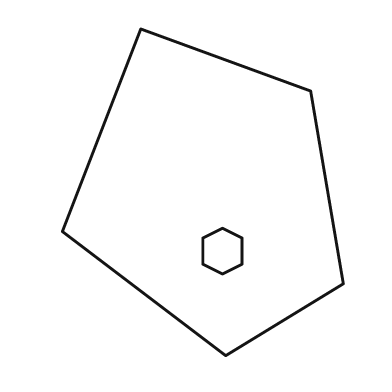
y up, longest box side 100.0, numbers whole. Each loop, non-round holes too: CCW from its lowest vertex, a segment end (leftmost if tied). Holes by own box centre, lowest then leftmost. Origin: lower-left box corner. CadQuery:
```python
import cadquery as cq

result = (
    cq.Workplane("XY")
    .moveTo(50.0, 0.0)
    .lineTo(86.0, 22.0)
    .lineTo(76.0, 81.0)
    .lineTo(24.0, 100.0)
    .lineTo(0.0, 38.0)
    .close()
    .moveTo(49.0, 25.0)
    .lineTo(55.0, 28.0)
    .lineTo(55.0, 36.0)
    .lineTo(49.0, 39.0)
    .lineTo(43.0, 36.0)
    .lineTo(43.0, 28.0)
    .close()
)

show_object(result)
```